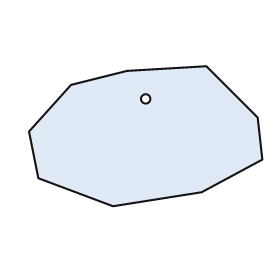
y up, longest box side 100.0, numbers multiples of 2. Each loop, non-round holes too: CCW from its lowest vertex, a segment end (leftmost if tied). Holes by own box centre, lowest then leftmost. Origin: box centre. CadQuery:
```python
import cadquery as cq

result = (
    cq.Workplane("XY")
    .moveTo(-14.0, -30.0)
    .lineTo(24.0, -24.0)
    .lineTo(50.0, -10.0)
    .lineTo(48.0, 8.0)
    .lineTo(26.0, 30.0)
    .lineTo(-8.0, 28.0)
    .lineTo(-32.0, 22.0)
    .lineTo(-50.0, 2.0)
    .lineTo(-46.0, -18.0)
    .close()
    .moveTo(0.0, 16.0)
    .circle(2.0)
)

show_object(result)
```